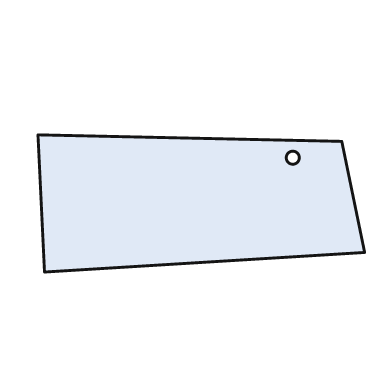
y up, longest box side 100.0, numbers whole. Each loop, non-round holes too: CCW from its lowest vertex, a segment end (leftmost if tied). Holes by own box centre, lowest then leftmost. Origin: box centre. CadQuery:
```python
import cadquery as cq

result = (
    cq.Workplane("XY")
    .moveTo(-48.0, -21.0)
    .lineTo(50.0, -15.0)
    .lineTo(43.0, 19.0)
    .lineTo(-50.0, 21.0)
    .close()
    .moveTo(28.0, 14.0)
    .circle(2.0)
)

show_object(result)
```